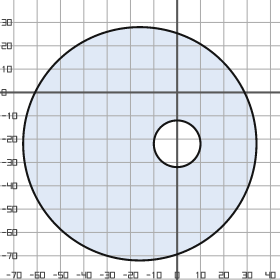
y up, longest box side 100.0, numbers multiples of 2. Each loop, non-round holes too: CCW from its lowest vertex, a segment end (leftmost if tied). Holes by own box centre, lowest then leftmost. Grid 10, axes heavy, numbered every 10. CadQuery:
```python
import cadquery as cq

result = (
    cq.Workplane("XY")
    .moveTo(-16.0, -22.0)
    .circle(50.0)
    .moveTo(0.0, -22.0)
    .circle(10.0)
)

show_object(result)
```